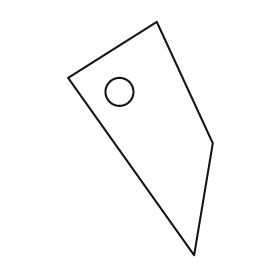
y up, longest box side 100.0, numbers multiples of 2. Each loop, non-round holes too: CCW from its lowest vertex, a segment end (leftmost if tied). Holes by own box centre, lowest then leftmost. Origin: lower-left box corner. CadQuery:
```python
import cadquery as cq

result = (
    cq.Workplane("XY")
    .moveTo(54.0, 0.0)
    .lineTo(62.0, 48.0)
    .lineTo(38.0, 100.0)
    .lineTo(0.0, 76.0)
    .close()
    .moveTo(22.0, 70.0)
    .circle(6.0)
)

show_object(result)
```